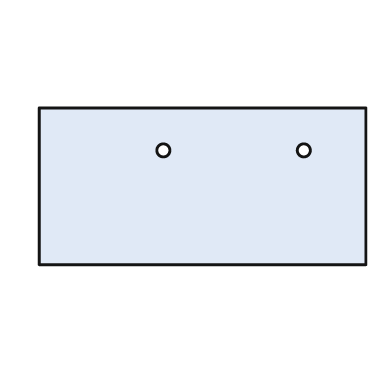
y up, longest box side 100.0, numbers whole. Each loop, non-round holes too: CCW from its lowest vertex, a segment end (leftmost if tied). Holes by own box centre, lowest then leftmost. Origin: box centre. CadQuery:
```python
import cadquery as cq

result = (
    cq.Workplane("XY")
    .moveTo(-50.0, -24.0)
    .lineTo(50.0, -24.0)
    .lineTo(50.0, 24.0)
    .lineTo(-50.0, 24.0)
    .close()
    .moveTo(-12.0, 11.0)
    .circle(2.0)
    .moveTo(31.0, 11.0)
    .circle(2.0)
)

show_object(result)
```